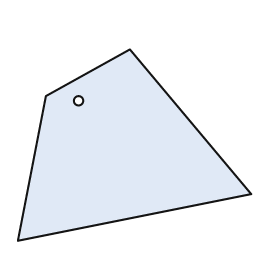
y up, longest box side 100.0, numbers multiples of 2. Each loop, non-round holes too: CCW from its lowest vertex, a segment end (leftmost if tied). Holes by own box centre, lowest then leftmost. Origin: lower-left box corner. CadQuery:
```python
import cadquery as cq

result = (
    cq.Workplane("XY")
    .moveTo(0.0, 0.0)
    .lineTo(100.0, 20.0)
    .lineTo(48.0, 82.0)
    .lineTo(12.0, 62.0)
    .close()
    .moveTo(26.0, 60.0)
    .circle(2.0)
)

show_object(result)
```